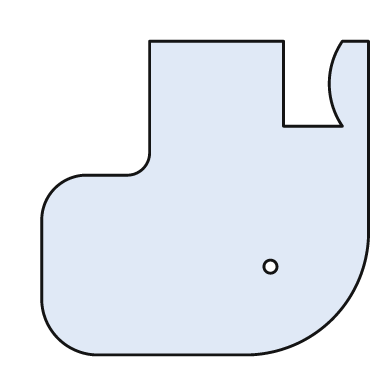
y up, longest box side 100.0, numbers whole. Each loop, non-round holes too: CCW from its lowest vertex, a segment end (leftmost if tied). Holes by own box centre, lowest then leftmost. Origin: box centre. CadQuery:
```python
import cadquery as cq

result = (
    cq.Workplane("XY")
    .moveTo(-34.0, -48.0)
    .lineTo(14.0, -48.0)
    .threePointArc((39.0, -37.0), (50.0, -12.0))
    .lineTo(50.0, 48.0)
    .lineTo(42.0, 48.0)
    .threePointArc((38.0, 35.0), (42.0, 22.0))
    .lineTo(24.0, 22.0)
    .lineTo(24.0, 48.0)
    .lineTo(-17.0, 48.0)
    .lineTo(-17.0, 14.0)
    .threePointArc((-19.0, 9.0), (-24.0, 7.0))
    .lineTo(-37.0, 7.0)
    .threePointArc((-46.0, 3.0), (-50.0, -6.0))
    .lineTo(-50.0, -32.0)
    .threePointArc((-45.0, -43.0), (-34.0, -48.0))
    .close()
    .moveTo(20.0, -21.0)
    .circle(2.0)
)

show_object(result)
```